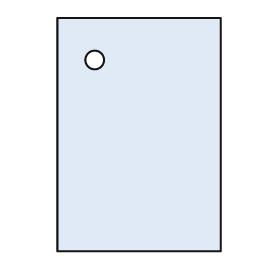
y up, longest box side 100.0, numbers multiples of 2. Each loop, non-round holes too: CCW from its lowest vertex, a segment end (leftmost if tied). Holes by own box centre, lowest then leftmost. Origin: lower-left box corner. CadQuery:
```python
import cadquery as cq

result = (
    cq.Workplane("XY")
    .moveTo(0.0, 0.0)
    .lineTo(70.0, 0.0)
    .lineTo(70.0, 100.0)
    .lineTo(0.0, 100.0)
    .close()
    .moveTo(16.0, 82.0)
    .circle(4.0)
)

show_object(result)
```